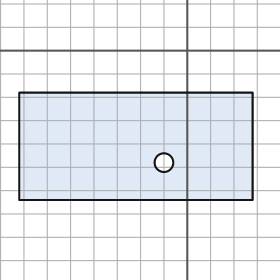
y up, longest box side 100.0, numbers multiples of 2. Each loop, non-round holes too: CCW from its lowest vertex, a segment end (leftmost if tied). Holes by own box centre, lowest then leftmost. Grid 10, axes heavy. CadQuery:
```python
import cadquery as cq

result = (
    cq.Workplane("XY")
    .moveTo(-72.0, -64.0)
    .lineTo(28.0, -64.0)
    .lineTo(28.0, -18.0)
    .lineTo(-72.0, -18.0)
    .close()
    .moveTo(-10.0, -48.0)
    .circle(4.0)
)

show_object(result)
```